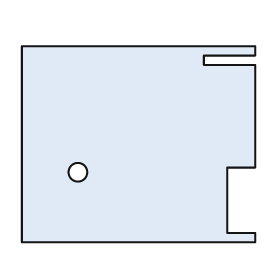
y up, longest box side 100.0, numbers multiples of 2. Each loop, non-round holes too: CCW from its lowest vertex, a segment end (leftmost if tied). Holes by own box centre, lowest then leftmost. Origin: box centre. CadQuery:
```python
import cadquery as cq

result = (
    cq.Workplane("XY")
    .moveTo(-50.0, -42.0)
    .lineTo(50.0, -42.0)
    .lineTo(50.0, -38.0)
    .lineTo(38.0, -38.0)
    .lineTo(38.0, -10.0)
    .lineTo(50.0, -10.0)
    .lineTo(50.0, 34.0)
    .lineTo(28.0, 34.0)
    .lineTo(28.0, 38.0)
    .lineTo(50.0, 38.0)
    .lineTo(50.0, 42.0)
    .lineTo(-50.0, 42.0)
    .close()
    .moveTo(-26.0, -12.0)
    .circle(4.0)
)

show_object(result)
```